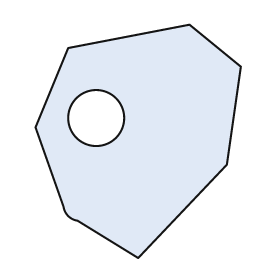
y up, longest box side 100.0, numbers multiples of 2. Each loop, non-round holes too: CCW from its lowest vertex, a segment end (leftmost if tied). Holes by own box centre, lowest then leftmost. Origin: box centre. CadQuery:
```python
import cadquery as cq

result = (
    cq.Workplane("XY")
    .moveTo(0.0, -50.0)
    .lineTo(38.0, -10.0)
    .lineTo(44.0, 32.0)
    .lineTo(22.0, 50.0)
    .lineTo(-30.0, 40.0)
    .lineTo(-44.0, 6.0)
    .lineTo(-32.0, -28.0)
    .threePointArc((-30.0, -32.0), (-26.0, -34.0))
    .close()
    .moveTo(-18.0, 10.0)
    .circle(12.0)
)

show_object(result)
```